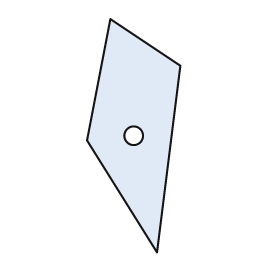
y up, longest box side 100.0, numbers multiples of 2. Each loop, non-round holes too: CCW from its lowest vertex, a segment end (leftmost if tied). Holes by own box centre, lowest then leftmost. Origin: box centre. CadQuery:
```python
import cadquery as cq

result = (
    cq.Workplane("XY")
    .moveTo(10.0, -50.0)
    .lineTo(20.0, 30.0)
    .lineTo(-10.0, 50.0)
    .lineTo(-20.0, -2.0)
    .close()
    .moveTo(0.0, 0.0)
    .circle(4.0)
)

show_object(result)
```